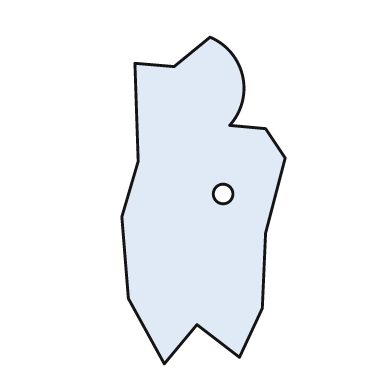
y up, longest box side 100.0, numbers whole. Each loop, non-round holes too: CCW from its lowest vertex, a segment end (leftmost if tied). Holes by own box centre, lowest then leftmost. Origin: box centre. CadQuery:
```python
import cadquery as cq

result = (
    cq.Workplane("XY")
    .moveTo(-12.0, -50.0)
    .lineTo(-2.0, -38.0)
    .lineTo(11.0, -48.0)
    .lineTo(18.0, -33.0)
    .lineTo(19.0, -10.0)
    .lineTo(25.0, 13.0)
    .lineTo(19.0, 22.0)
    .lineTo(8.0, 23.0)
    .threePointArc((12.0, 38.0), (2.0, 50.0))
    .lineTo(-9.0, 41.0)
    .lineTo(-21.0, 42.0)
    .lineTo(-20.0, 12.0)
    .lineTo(-25.0, -5.0)
    .lineTo(-23.0, -30.0)
    .close()
    .moveTo(6.0, 2.0)
    .circle(3.0)
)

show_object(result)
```